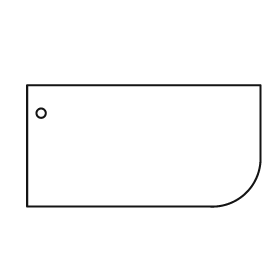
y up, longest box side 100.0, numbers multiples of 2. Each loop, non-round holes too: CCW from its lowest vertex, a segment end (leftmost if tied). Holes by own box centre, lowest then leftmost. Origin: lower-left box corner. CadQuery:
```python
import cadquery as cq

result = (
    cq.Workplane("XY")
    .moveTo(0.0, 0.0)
    .lineTo(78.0, 0.0)
    .threePointArc((94.0, 6.0), (100.0, 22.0))
    .lineTo(100.0, 52.0)
    .lineTo(0.0, 52.0)
    .close()
    .moveTo(6.0, 40.0)
    .circle(2.0)
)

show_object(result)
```